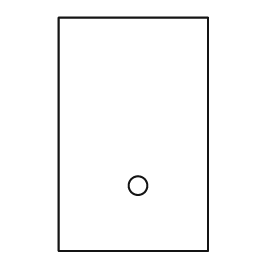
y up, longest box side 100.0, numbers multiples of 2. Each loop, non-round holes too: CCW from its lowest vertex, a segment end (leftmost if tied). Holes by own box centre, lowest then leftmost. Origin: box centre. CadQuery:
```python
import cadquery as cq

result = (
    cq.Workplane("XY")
    .moveTo(-32.0, -50.0)
    .lineTo(32.0, -50.0)
    .lineTo(32.0, 50.0)
    .lineTo(-32.0, 50.0)
    .close()
    .moveTo(2.0, -22.0)
    .circle(4.0)
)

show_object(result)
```